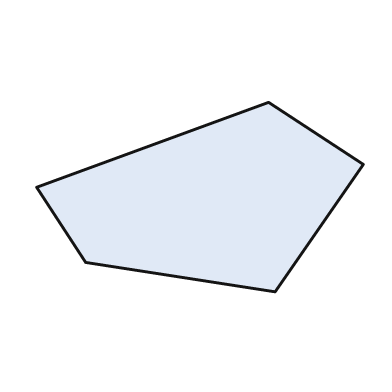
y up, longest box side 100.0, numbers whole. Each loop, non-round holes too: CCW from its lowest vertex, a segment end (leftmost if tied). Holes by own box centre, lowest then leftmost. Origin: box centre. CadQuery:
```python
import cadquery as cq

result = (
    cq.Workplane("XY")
    .moveTo(23.0, -29.0)
    .lineTo(50.0, 10.0)
    .lineTo(21.0, 29.0)
    .lineTo(-50.0, 3.0)
    .lineTo(-35.0, -20.0)
    .close()
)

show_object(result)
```